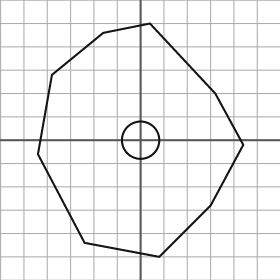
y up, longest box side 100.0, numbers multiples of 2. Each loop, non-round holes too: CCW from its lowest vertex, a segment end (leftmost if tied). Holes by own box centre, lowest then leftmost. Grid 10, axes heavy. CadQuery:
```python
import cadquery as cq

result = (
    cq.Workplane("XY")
    .moveTo(8.0, -50.0)
    .lineTo(30.0, -28.0)
    .lineTo(44.0, -2.0)
    .lineTo(32.0, 20.0)
    .lineTo(4.0, 50.0)
    .lineTo(-16.0, 46.0)
    .lineTo(-38.0, 28.0)
    .lineTo(-44.0, -6.0)
    .lineTo(-24.0, -44.0)
    .close()
    .moveTo(0.0, 0.0)
    .circle(8.0)
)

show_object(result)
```